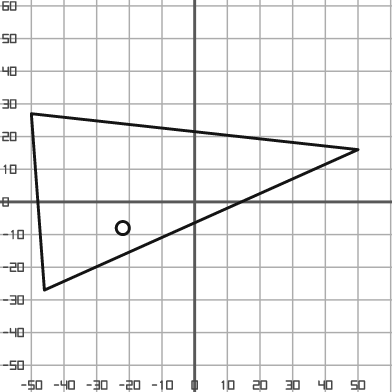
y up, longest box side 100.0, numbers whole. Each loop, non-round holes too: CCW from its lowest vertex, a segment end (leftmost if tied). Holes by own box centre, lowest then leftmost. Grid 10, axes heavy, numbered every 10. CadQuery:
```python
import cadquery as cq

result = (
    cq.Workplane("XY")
    .moveTo(-46.0, -27.0)
    .lineTo(50.0, 16.0)
    .lineTo(-50.0, 27.0)
    .close()
    .moveTo(-22.0, -8.0)
    .circle(2.0)
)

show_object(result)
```